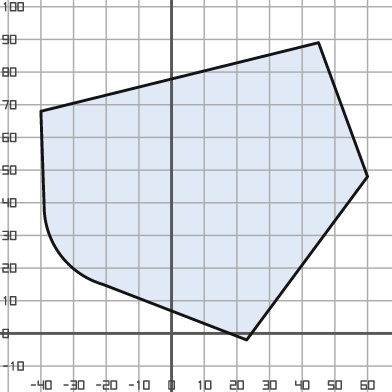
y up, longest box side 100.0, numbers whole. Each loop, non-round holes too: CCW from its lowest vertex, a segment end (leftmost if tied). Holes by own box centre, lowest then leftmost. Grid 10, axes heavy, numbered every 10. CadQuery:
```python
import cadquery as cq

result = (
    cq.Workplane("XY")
    .moveTo(23.0, -2.0)
    .lineTo(60.0, 48.0)
    .lineTo(45.0, 89.0)
    .lineTo(-40.0, 68.0)
    .lineTo(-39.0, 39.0)
    .threePointArc((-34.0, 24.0), (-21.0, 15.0))
    .close()
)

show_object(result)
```